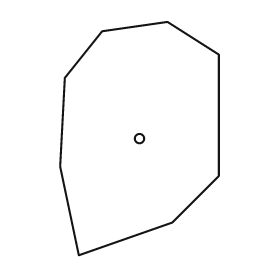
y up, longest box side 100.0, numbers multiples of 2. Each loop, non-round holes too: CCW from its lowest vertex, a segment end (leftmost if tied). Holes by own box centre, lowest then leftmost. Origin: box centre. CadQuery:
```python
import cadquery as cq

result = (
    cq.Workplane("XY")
    .moveTo(-26.0, -50.0)
    .lineTo(14.0, -36.0)
    .lineTo(34.0, -16.0)
    .lineTo(34.0, 36.0)
    .lineTo(12.0, 50.0)
    .lineTo(-16.0, 46.0)
    .lineTo(-32.0, 26.0)
    .lineTo(-34.0, -12.0)
    .close()
    .moveTo(0.0, 0.0)
    .circle(2.0)
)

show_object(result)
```